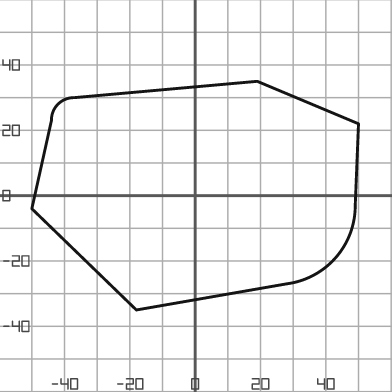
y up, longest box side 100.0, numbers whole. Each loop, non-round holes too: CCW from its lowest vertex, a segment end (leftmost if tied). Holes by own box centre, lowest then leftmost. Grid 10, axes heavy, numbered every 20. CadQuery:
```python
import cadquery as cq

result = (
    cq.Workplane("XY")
    .moveTo(-18.0, -35.0)
    .lineTo(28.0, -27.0)
    .threePointArc((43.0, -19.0), (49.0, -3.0))
    .lineTo(50.0, 22.0)
    .lineTo(19.0, 35.0)
    .lineTo(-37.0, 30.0)
    .threePointArc((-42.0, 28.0), (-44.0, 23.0))
    .lineTo(-50.0, -4.0)
    .close()
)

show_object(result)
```